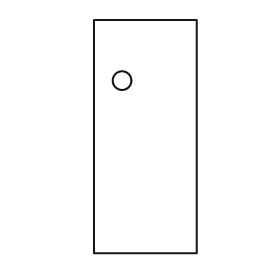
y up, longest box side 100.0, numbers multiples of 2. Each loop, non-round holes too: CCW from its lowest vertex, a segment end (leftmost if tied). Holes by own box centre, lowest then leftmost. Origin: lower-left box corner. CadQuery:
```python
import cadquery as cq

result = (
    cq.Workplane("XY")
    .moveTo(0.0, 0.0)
    .lineTo(44.0, 0.0)
    .lineTo(44.0, 100.0)
    .lineTo(0.0, 100.0)
    .close()
    .moveTo(12.0, 74.0)
    .circle(4.0)
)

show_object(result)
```